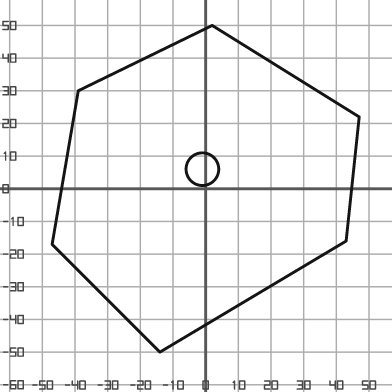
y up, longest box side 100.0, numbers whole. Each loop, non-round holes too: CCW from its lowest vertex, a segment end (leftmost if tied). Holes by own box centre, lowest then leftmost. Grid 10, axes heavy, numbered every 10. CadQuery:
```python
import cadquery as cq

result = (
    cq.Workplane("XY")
    .moveTo(-14.0, -50.0)
    .lineTo(43.0, -16.0)
    .lineTo(47.0, 22.0)
    .lineTo(2.0, 50.0)
    .lineTo(-39.0, 30.0)
    .lineTo(-47.0, -17.0)
    .close()
    .moveTo(-1.0, 6.0)
    .circle(5.0)
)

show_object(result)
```